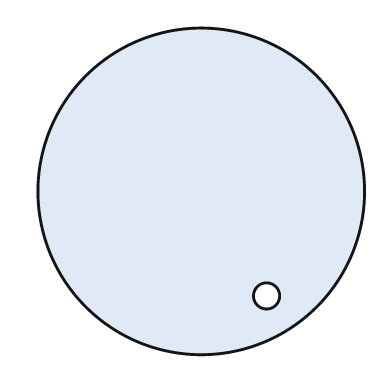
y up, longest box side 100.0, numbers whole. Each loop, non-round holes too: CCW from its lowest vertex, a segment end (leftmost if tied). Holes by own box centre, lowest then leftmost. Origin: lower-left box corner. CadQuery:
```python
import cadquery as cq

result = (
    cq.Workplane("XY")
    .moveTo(50.0, 50.0)
    .circle(50.0)
    .moveTo(70.0, 18.0)
    .circle(4.0)
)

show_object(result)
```